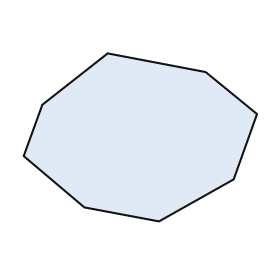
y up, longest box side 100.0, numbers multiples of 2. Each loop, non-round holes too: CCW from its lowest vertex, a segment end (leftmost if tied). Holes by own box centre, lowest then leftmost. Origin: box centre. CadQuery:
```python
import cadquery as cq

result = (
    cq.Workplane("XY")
    .moveTo(8.0, -36.0)
    .lineTo(40.0, -18.0)
    .lineTo(50.0, 10.0)
    .lineTo(28.0, 28.0)
    .lineTo(-14.0, 36.0)
    .lineTo(-42.0, 14.0)
    .lineTo(-50.0, -8.0)
    .lineTo(-24.0, -30.0)
    .close()
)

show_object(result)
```